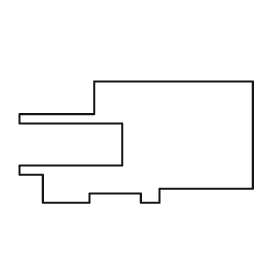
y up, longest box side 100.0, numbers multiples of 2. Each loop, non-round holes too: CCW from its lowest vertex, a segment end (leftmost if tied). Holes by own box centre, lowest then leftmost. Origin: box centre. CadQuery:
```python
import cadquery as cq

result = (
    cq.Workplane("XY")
    .moveTo(-40.0, -26.0)
    .lineTo(-20.0, -26.0)
    .lineTo(-20.0, -22.0)
    .lineTo(2.0, -22.0)
    .lineTo(2.0, -26.0)
    .lineTo(10.0, -26.0)
    .lineTo(10.0, -20.0)
    .lineTo(50.0, -20.0)
    .lineTo(50.0, 26.0)
    .lineTo(-18.0, 26.0)
    .lineTo(-18.0, 12.0)
    .lineTo(-50.0, 12.0)
    .lineTo(-50.0, 8.0)
    .lineTo(-6.0, 8.0)
    .lineTo(-6.0, -10.0)
    .lineTo(-50.0, -10.0)
    .lineTo(-50.0, -14.0)
    .lineTo(-40.0, -14.0)
    .close()
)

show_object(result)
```